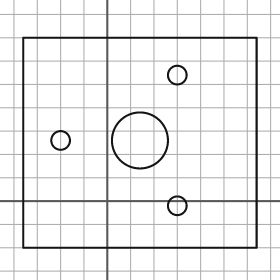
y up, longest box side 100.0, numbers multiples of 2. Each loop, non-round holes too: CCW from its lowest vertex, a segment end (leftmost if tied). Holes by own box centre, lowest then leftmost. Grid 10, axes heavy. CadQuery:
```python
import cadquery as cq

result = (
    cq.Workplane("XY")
    .moveTo(-36.0, -20.0)
    .lineTo(64.0, -20.0)
    .lineTo(64.0, 70.0)
    .lineTo(-36.0, 70.0)
    .close()
    .moveTo(30.0, -2.0)
    .circle(4.0)
    .moveTo(-20.0, 26.0)
    .circle(4.0)
    .moveTo(14.0, 26.0)
    .circle(12.0)
    .moveTo(30.0, 54.0)
    .circle(4.0)
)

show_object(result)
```